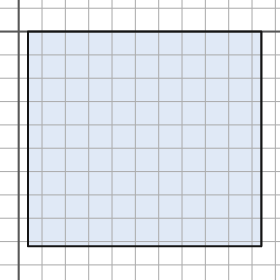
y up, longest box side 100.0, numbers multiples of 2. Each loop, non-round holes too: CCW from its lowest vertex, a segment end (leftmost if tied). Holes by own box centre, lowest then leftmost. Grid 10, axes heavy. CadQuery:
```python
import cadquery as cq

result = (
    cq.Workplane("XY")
    .moveTo(4.0, -92.0)
    .lineTo(104.0, -92.0)
    .lineTo(104.0, 0.0)
    .lineTo(4.0, 0.0)
    .close()
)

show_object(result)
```